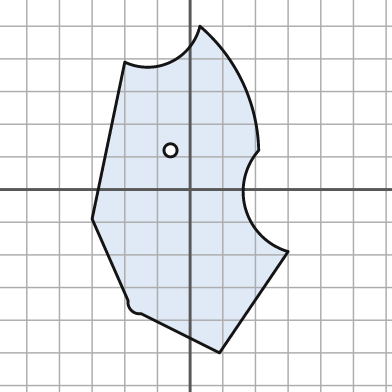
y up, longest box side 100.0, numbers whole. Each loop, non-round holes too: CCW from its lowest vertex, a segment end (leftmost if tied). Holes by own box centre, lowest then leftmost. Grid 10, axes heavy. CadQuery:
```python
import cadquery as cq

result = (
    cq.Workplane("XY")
    .moveTo(9.0, -50.0)
    .lineTo(30.0, -19.0)
    .threePointArc((17.0, -6.0), (21.0, 12.0))
    .threePointArc((16.0, 33.0), (3.0, 50.0))
    .threePointArc((-6.0, 39.0), (-20.0, 39.0))
    .lineTo(-30.0, -9.0)
    .lineTo(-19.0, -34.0)
    .threePointArc((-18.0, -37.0), (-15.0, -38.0))
    .close()
    .moveTo(-6.0, 12.0)
    .circle(2.0)
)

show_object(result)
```